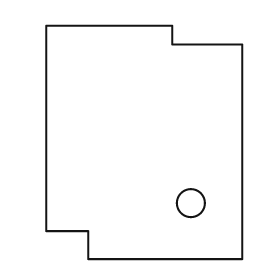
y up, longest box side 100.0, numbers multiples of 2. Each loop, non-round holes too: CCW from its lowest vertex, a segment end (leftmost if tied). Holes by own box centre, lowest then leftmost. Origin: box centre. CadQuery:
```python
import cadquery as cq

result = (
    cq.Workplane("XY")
    .moveTo(-24.0, -50.0)
    .lineTo(42.0, -50.0)
    .lineTo(42.0, 42.0)
    .lineTo(12.0, 42.0)
    .lineTo(12.0, 50.0)
    .lineTo(-42.0, 50.0)
    .lineTo(-42.0, -38.0)
    .lineTo(-24.0, -38.0)
    .close()
    .moveTo(20.0, -26.0)
    .circle(6.0)
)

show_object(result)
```